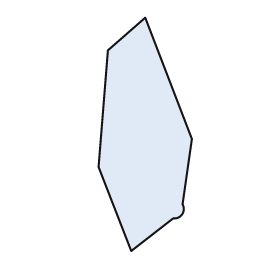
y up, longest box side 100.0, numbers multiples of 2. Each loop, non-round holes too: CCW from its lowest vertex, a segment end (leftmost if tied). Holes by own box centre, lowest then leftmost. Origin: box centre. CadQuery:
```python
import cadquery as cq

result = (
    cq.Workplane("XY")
    .moveTo(-6.0, -50.0)
    .lineTo(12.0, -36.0)
    .threePointArc((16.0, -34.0), (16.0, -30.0))
    .lineTo(20.0, -2.0)
    .lineTo(0.0, 50.0)
    .lineTo(-16.0, 36.0)
    .lineTo(-20.0, -14.0)
    .close()
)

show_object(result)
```